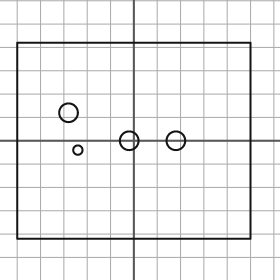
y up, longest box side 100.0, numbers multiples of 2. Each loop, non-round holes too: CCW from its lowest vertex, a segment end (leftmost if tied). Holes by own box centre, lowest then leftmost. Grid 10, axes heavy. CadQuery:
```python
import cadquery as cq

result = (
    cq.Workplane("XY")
    .moveTo(-50.0, -42.0)
    .lineTo(50.0, -42.0)
    .lineTo(50.0, 42.0)
    .lineTo(-50.0, 42.0)
    .close()
    .moveTo(-24.0, -4.0)
    .circle(2.0)
    .moveTo(-2.0, 0.0)
    .circle(4.0)
    .moveTo(18.0, 0.0)
    .circle(4.0)
    .moveTo(-28.0, 12.0)
    .circle(4.0)
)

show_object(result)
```